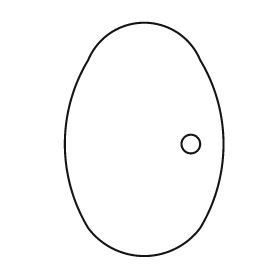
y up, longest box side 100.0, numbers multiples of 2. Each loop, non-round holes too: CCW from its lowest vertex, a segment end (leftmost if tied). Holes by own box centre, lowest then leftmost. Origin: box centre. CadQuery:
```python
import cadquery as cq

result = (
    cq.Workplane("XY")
    .moveTo(-24.0, -38.0)
    .threePointArc((0.0, -50.0), (24.0, -38.0))
    .threePointArc((34.0, -2.0), (24.0, 34.0))
    .threePointArc((0.0, 50.0), (-24.0, 34.0))
    .threePointArc((-34.0, -2.0), (-24.0, -38.0))
    .close()
    .moveTo(20.0, -2.0)
    .circle(4.0)
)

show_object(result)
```